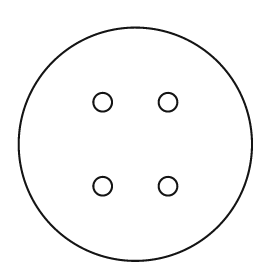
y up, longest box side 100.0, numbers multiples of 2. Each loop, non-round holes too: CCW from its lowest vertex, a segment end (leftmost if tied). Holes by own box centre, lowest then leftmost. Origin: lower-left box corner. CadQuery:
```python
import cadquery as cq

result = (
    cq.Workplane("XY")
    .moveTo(50.0, 50.0)
    .circle(50.0)
    .moveTo(36.0, 32.0)
    .circle(4.0)
    .moveTo(64.0, 32.0)
    .circle(4.0)
    .moveTo(36.0, 68.0)
    .circle(4.0)
    .moveTo(64.0, 68.0)
    .circle(4.0)
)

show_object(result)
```